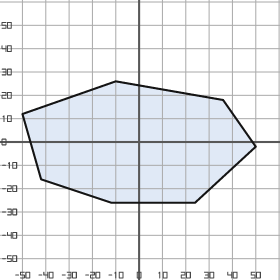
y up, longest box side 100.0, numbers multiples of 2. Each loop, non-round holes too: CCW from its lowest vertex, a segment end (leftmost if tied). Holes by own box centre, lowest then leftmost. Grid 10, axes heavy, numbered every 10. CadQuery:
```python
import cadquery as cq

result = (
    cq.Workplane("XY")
    .moveTo(-12.0, -26.0)
    .lineTo(24.0, -26.0)
    .lineTo(50.0, -2.0)
    .lineTo(36.0, 18.0)
    .lineTo(-10.0, 26.0)
    .lineTo(-50.0, 12.0)
    .lineTo(-42.0, -16.0)
    .close()
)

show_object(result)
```